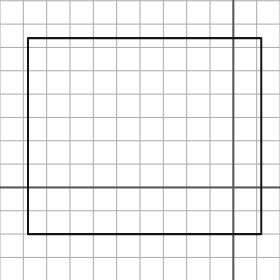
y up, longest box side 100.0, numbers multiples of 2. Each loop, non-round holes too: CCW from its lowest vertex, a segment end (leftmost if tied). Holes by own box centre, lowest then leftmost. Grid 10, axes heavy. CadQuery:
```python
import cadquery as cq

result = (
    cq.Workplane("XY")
    .moveTo(-88.0, -20.0)
    .lineTo(12.0, -20.0)
    .lineTo(12.0, 64.0)
    .lineTo(-88.0, 64.0)
    .close()
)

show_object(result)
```